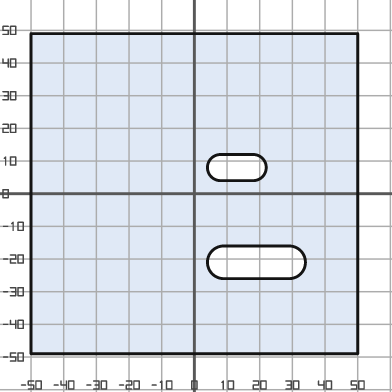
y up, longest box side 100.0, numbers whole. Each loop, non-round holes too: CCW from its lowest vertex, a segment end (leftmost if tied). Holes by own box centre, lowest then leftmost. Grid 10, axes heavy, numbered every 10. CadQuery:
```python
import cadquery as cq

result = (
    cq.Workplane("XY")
    .moveTo(-50.0, -49.0)
    .lineTo(50.0, -49.0)
    .lineTo(50.0, 49.0)
    .lineTo(-50.0, 49.0)
    .close()
    .moveTo(9.0, -26.0)
    .lineTo(29.0, -26.0)
    .threePointArc((34.0, -21.0), (29.0, -16.0))
    .lineTo(9.0, -16.0)
    .threePointArc((4.0, -21.0), (9.0, -26.0))
    .close()
    .moveTo(8.0, 4.0)
    .lineTo(18.0, 4.0)
    .threePointArc((22.0, 8.0), (18.0, 12.0))
    .lineTo(8.0, 12.0)
    .threePointArc((4.0, 8.0), (8.0, 4.0))
    .close()
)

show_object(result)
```